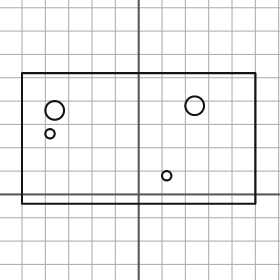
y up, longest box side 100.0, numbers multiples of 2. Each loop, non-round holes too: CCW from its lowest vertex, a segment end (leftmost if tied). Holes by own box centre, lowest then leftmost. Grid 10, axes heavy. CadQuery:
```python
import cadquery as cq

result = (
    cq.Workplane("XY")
    .moveTo(-50.0, -4.0)
    .lineTo(50.0, -4.0)
    .lineTo(50.0, 52.0)
    .lineTo(-50.0, 52.0)
    .close()
    .moveTo(12.0, 8.0)
    .circle(2.0)
    .moveTo(-38.0, 26.0)
    .circle(2.0)
    .moveTo(-36.0, 36.0)
    .circle(4.0)
    .moveTo(24.0, 38.0)
    .circle(4.0)
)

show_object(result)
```